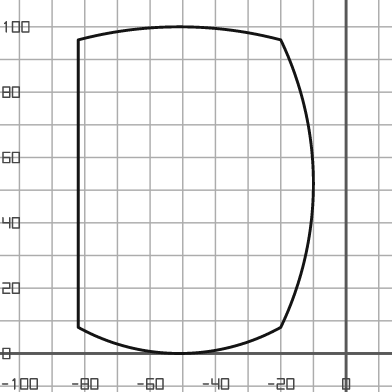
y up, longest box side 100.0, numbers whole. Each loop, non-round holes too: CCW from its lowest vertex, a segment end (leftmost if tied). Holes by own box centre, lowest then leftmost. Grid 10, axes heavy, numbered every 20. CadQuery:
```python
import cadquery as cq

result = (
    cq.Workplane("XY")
    .moveTo(-82.0, 8.0)
    .threePointArc((-51.0, 0.0), (-20.0, 8.0))
    .threePointArc((-10.0, 52.0), (-20.0, 96.0))
    .threePointArc((-51.0, 100.0), (-82.0, 96.0))
    .close()
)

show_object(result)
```